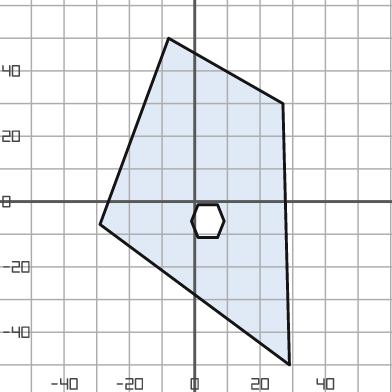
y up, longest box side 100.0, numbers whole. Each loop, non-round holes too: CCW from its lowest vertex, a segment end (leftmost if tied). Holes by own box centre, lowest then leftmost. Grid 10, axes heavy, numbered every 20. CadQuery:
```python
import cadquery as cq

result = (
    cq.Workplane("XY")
    .moveTo(29.0, -50.0)
    .lineTo(27.0, 30.0)
    .lineTo(-8.0, 50.0)
    .lineTo(-29.0, -7.0)
    .close()
    .moveTo(1.0, -11.0)
    .lineTo(7.0, -11.0)
    .lineTo(9.0, -6.0)
    .lineTo(7.0, -1.0)
    .lineTo(1.0, -1.0)
    .lineTo(-1.0, -6.0)
    .close()
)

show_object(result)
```